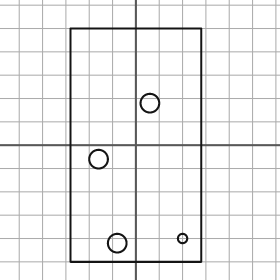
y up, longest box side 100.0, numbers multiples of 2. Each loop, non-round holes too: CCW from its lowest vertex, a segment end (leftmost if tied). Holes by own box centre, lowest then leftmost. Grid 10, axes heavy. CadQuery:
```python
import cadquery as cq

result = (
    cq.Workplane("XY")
    .moveTo(-28.0, -50.0)
    .lineTo(28.0, -50.0)
    .lineTo(28.0, 50.0)
    .lineTo(-28.0, 50.0)
    .close()
    .moveTo(-8.0, -42.0)
    .circle(4.0)
    .moveTo(20.0, -40.0)
    .circle(2.0)
    .moveTo(-16.0, -6.0)
    .circle(4.0)
    .moveTo(6.0, 18.0)
    .circle(4.0)
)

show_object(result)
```